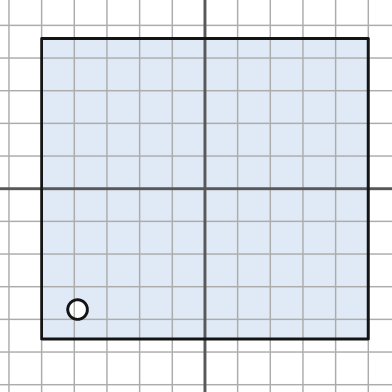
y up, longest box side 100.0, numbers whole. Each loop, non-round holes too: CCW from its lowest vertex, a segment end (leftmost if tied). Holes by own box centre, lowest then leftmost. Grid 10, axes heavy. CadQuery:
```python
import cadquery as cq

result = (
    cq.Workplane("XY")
    .moveTo(-50.0, -46.0)
    .lineTo(50.0, -46.0)
    .lineTo(50.0, 46.0)
    .lineTo(-50.0, 46.0)
    .close()
    .moveTo(-39.0, -37.0)
    .circle(3.0)
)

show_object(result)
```